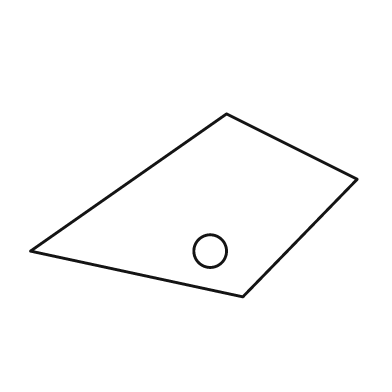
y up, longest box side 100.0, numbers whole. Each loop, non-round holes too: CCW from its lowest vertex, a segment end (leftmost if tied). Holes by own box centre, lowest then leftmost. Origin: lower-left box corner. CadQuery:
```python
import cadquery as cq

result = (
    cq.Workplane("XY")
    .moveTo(65.0, 0.0)
    .lineTo(100.0, 36.0)
    .lineTo(60.0, 56.0)
    .lineTo(0.0, 14.0)
    .close()
    .moveTo(55.0, 14.0)
    .circle(5.0)
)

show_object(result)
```